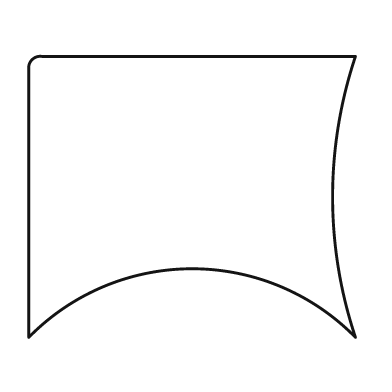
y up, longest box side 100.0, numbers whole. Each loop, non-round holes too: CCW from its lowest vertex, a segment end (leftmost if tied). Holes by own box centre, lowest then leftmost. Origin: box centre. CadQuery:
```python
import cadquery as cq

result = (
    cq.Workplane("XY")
    .moveTo(-50.0, -43.0)
    .threePointArc((0.0, -22.0), (50.0, -43.0))
    .threePointArc((43.0, 0.0), (50.0, 43.0))
    .lineTo(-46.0, 43.0)
    .threePointArc((-49.0, 42.0), (-50.0, 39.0))
    .close()
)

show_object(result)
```